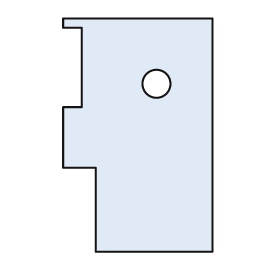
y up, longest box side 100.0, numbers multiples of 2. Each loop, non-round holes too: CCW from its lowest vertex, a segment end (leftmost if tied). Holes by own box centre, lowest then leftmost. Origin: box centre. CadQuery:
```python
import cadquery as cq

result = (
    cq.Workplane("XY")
    .moveTo(-18.0, -50.0)
    .lineTo(32.0, -50.0)
    .lineTo(32.0, 50.0)
    .lineTo(-32.0, 50.0)
    .lineTo(-32.0, 46.0)
    .lineTo(-24.0, 46.0)
    .lineTo(-24.0, 12.0)
    .lineTo(-32.0, 12.0)
    .lineTo(-32.0, -14.0)
    .lineTo(-18.0, -14.0)
    .close()
    .moveTo(8.0, 22.0)
    .circle(6.0)
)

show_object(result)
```